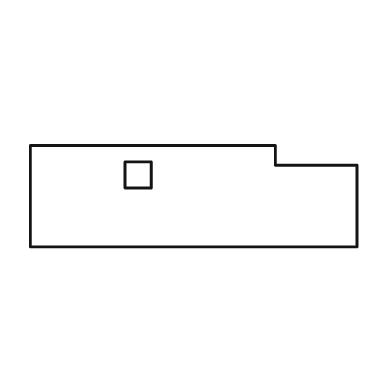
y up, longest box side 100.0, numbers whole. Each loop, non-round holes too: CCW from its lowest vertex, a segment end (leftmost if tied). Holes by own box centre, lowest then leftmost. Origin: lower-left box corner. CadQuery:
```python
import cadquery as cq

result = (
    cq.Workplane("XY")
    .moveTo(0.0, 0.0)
    .lineTo(100.0, 0.0)
    .lineTo(100.0, 25.0)
    .lineTo(75.0, 25.0)
    .lineTo(75.0, 31.0)
    .lineTo(0.0, 31.0)
    .close()
    .moveTo(29.0, 18.0)
    .lineTo(37.0, 18.0)
    .lineTo(37.0, 26.0)
    .lineTo(29.0, 26.0)
    .close()
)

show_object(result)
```